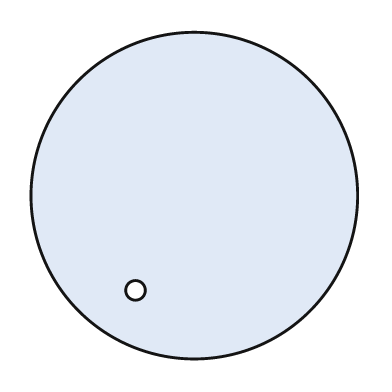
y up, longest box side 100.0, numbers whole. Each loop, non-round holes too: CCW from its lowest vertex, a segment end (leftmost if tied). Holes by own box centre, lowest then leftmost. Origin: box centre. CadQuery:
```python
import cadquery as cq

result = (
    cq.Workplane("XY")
    .moveTo(0.0, 0.0)
    .circle(50.0)
    .moveTo(-18.0, -29.0)
    .circle(3.0)
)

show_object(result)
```